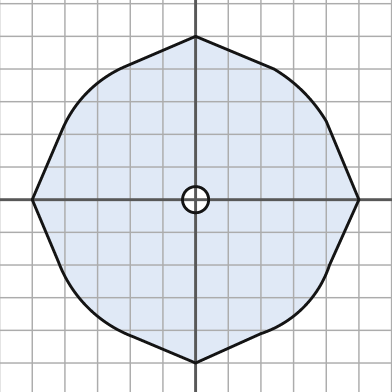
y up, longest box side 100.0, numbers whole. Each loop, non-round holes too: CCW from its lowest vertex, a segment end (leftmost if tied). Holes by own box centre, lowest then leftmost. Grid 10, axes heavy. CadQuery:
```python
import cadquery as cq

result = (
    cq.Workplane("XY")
    .moveTo(0.0, -50.0)
    .lineTo(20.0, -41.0)
    .threePointArc((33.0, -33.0), (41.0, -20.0))
    .lineTo(50.0, 0.0)
    .lineTo(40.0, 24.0)
    .threePointArc((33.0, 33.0), (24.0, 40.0))
    .lineTo(0.0, 50.0)
    .lineTo(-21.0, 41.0)
    .threePointArc((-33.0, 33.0), (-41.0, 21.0))
    .lineTo(-50.0, 0.0)
    .lineTo(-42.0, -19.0)
    .threePointArc((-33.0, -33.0), (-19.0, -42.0))
    .close()
    .moveTo(0.0, 0.0)
    .circle(4.0)
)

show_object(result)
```